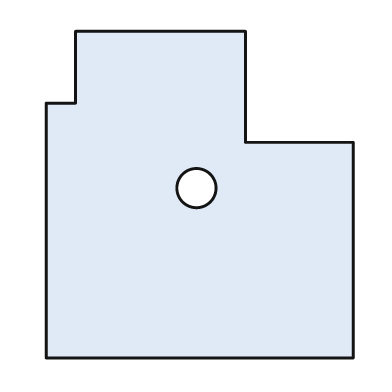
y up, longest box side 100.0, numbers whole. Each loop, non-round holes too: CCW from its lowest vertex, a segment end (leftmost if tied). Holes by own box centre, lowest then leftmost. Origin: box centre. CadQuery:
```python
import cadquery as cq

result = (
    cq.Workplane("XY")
    .moveTo(-47.0, -50.0)
    .lineTo(47.0, -50.0)
    .lineTo(47.0, 16.0)
    .lineTo(14.0, 16.0)
    .lineTo(14.0, 50.0)
    .lineTo(-38.0, 50.0)
    .lineTo(-38.0, 28.0)
    .lineTo(-47.0, 28.0)
    .close()
    .moveTo(-1.0, 2.0)
    .circle(6.0)
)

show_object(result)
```